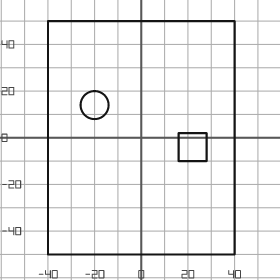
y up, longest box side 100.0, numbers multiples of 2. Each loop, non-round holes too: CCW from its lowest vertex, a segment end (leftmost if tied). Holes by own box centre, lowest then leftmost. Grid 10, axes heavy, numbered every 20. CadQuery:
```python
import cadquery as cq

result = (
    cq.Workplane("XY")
    .moveTo(-40.0, -50.0)
    .lineTo(40.0, -50.0)
    .lineTo(40.0, 50.0)
    .lineTo(-40.0, 50.0)
    .close()
    .moveTo(16.0, -10.0)
    .lineTo(28.0, -10.0)
    .lineTo(28.0, 2.0)
    .lineTo(16.0, 2.0)
    .close()
    .moveTo(-20.0, 14.0)
    .circle(6.0)
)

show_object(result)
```